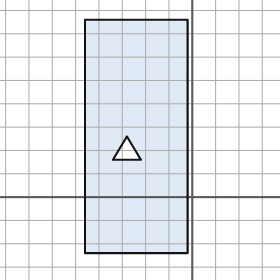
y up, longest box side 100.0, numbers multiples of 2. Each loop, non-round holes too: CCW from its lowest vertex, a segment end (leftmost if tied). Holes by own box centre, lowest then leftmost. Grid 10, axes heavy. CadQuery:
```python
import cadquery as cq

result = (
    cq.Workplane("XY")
    .moveTo(-46.0, -24.0)
    .lineTo(-2.0, -24.0)
    .lineTo(-2.0, 76.0)
    .lineTo(-46.0, 76.0)
    .close()
    .moveTo(-34.0, 16.0)
    .lineTo(-22.0, 16.0)
    .lineTo(-28.0, 26.0)
    .close()
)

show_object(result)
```